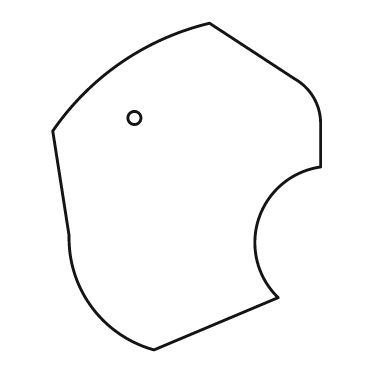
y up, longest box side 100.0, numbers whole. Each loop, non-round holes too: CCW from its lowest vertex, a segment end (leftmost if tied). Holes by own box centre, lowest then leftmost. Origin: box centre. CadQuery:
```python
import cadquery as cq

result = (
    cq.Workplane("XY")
    .moveTo(-10.0, -50.0)
    .lineTo(28.0, -34.0)
    .threePointArc((22.0, -10.0), (41.0, 6.0))
    .lineTo(41.0, 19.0)
    .threePointArc((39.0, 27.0), (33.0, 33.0))
    .lineTo(7.0, 50.0)
    .threePointArc((-20.0, 38.0), (-41.0, 17.0))
    .lineTo(-36.0, -15.0)
    .threePointArc((-29.0, -37.0), (-10.0, -50.0))
    .close()
    .moveTo(-16.0, 21.0)
    .circle(2.0)
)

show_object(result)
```